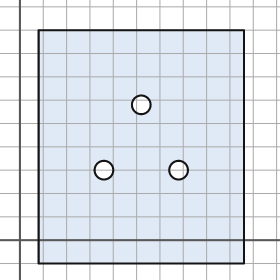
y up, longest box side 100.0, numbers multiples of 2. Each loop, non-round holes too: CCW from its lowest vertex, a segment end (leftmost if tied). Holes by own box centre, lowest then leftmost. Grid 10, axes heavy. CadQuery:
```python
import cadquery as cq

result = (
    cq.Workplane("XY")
    .moveTo(8.0, -10.0)
    .lineTo(96.0, -10.0)
    .lineTo(96.0, 90.0)
    .lineTo(8.0, 90.0)
    .close()
    .moveTo(36.0, 30.0)
    .circle(4.0)
    .moveTo(68.0, 30.0)
    .circle(4.0)
    .moveTo(52.0, 58.0)
    .circle(4.0)
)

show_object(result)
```